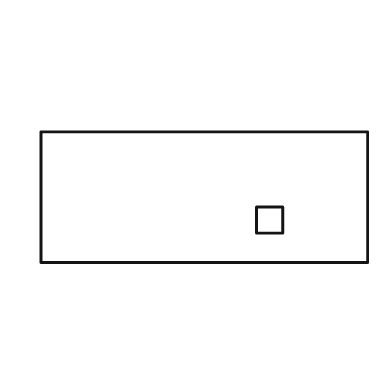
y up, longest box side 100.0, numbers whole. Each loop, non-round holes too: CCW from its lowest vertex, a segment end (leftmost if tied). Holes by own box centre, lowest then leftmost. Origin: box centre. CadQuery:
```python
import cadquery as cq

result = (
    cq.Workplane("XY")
    .moveTo(-50.0, -20.0)
    .lineTo(50.0, -20.0)
    .lineTo(50.0, 20.0)
    .lineTo(-50.0, 20.0)
    .close()
    .moveTo(16.0, -11.0)
    .lineTo(24.0, -11.0)
    .lineTo(24.0, -3.0)
    .lineTo(16.0, -3.0)
    .close()
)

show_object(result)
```